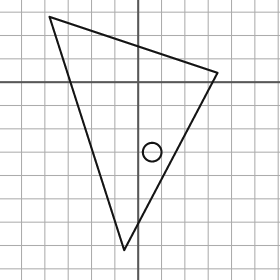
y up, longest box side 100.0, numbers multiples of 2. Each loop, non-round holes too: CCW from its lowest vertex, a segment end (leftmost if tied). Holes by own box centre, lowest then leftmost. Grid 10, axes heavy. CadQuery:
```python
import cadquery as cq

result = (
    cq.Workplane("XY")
    .moveTo(-6.0, -72.0)
    .lineTo(34.0, 4.0)
    .lineTo(-38.0, 28.0)
    .close()
    .moveTo(6.0, -30.0)
    .circle(4.0)
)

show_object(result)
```